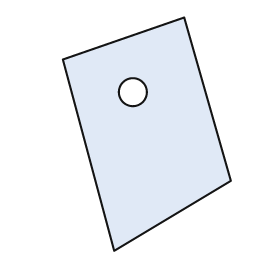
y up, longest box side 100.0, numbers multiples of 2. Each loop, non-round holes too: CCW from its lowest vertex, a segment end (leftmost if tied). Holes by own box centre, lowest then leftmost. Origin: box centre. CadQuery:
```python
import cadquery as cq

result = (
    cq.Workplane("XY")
    .moveTo(-14.0, -50.0)
    .lineTo(36.0, -20.0)
    .lineTo(16.0, 50.0)
    .lineTo(-36.0, 32.0)
    .close()
    .moveTo(-6.0, 18.0)
    .circle(6.0)
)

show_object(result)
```